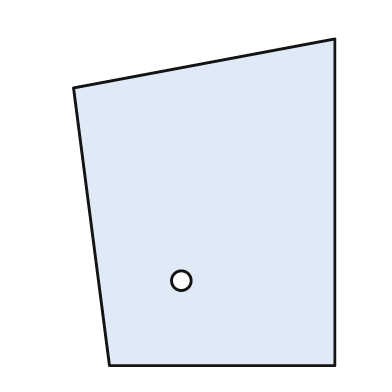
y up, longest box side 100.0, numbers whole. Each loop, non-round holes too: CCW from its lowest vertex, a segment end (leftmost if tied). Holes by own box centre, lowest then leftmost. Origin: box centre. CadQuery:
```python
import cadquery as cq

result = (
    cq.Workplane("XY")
    .moveTo(-29.0, -50.0)
    .lineTo(40.0, -50.0)
    .lineTo(40.0, 50.0)
    .lineTo(-40.0, 35.0)
    .close()
    .moveTo(-7.0, -24.0)
    .circle(3.0)
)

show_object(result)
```